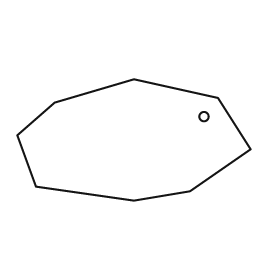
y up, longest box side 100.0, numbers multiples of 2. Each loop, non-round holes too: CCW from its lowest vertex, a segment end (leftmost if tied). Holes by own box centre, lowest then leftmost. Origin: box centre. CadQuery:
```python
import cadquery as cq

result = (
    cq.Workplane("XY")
    .moveTo(0.0, -26.0)
    .lineTo(24.0, -22.0)
    .lineTo(50.0, -4.0)
    .lineTo(36.0, 18.0)
    .lineTo(0.0, 26.0)
    .lineTo(-34.0, 16.0)
    .lineTo(-50.0, 2.0)
    .lineTo(-42.0, -20.0)
    .close()
    .moveTo(30.0, 10.0)
    .circle(2.0)
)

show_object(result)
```